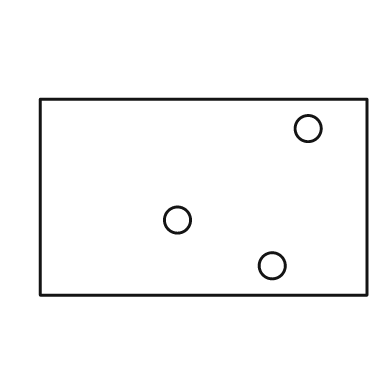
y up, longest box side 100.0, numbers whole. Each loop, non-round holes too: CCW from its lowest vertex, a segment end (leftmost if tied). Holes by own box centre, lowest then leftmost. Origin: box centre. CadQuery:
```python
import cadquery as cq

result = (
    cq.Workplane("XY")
    .moveTo(-50.0, -30.0)
    .lineTo(50.0, -30.0)
    .lineTo(50.0, 30.0)
    .lineTo(-50.0, 30.0)
    .close()
    .moveTo(21.0, -21.0)
    .circle(4.0)
    .moveTo(-8.0, -7.0)
    .circle(4.0)
    .moveTo(32.0, 21.0)
    .circle(4.0)
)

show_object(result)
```